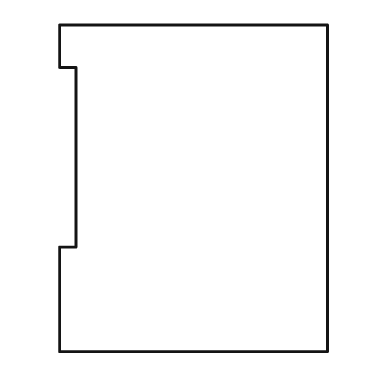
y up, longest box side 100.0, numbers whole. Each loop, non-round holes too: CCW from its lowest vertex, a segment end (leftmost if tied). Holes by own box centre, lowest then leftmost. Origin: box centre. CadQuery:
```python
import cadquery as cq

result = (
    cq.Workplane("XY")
    .moveTo(-41.0, -50.0)
    .lineTo(41.0, -50.0)
    .lineTo(41.0, 50.0)
    .lineTo(-41.0, 50.0)
    .lineTo(-41.0, 37.0)
    .lineTo(-36.0, 37.0)
    .lineTo(-36.0, -18.0)
    .lineTo(-41.0, -18.0)
    .close()
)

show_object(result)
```